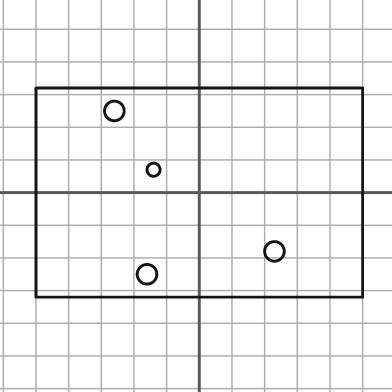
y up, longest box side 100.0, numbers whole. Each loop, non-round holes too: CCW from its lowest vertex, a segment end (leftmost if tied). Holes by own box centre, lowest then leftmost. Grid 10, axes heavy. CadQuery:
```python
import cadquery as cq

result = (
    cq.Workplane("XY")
    .moveTo(-50.0, -32.0)
    .lineTo(50.0, -32.0)
    .lineTo(50.0, 32.0)
    .lineTo(-50.0, 32.0)
    .close()
    .moveTo(-16.0, -25.0)
    .circle(3.0)
    .moveTo(23.0, -18.0)
    .circle(3.0)
    .moveTo(-14.0, 7.0)
    .circle(2.0)
    .moveTo(-26.0, 25.0)
    .circle(3.0)
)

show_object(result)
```